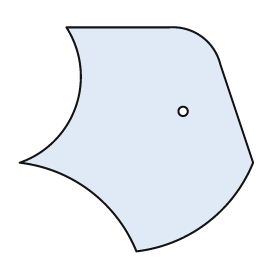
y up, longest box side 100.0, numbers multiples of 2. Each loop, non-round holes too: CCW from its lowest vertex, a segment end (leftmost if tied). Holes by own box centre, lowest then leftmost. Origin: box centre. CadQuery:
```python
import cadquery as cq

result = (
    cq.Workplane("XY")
    .moveTo(0.0, -48.0)
    .threePointArc((30.0, -36.0), (50.0, -10.0))
    .lineTo(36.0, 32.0)
    .threePointArc((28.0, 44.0), (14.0, 48.0))
    .lineTo(-30.0, 48.0)
    .threePointArc((-26.0, 14.0), (-50.0, -10.0))
    .threePointArc((-20.0, -22.0), (0.0, -48.0))
    .close()
    .moveTo(20.0, 12.0)
    .circle(2.0)
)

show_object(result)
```